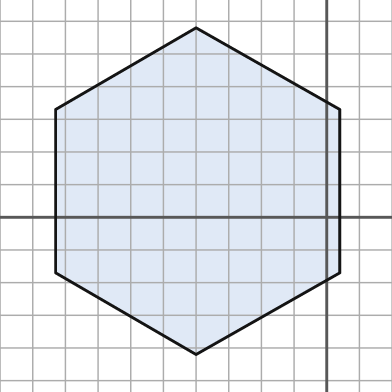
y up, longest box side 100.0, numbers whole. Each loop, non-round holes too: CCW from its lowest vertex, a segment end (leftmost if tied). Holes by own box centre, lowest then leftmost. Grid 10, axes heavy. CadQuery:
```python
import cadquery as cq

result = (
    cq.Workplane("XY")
    .moveTo(-40.0, -42.0)
    .lineTo(4.0, -17.0)
    .lineTo(4.0, 33.0)
    .lineTo(-40.0, 58.0)
    .lineTo(-83.0, 33.0)
    .lineTo(-83.0, -17.0)
    .close()
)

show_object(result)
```